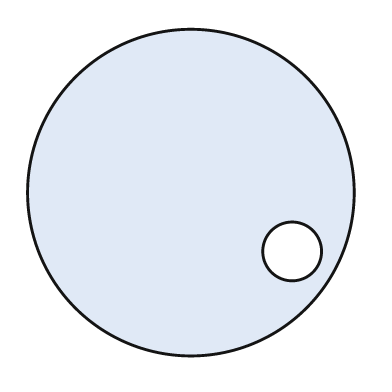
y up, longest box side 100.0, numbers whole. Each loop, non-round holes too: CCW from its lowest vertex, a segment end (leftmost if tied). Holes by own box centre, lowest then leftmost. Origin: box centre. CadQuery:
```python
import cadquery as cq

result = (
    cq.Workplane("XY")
    .moveTo(0.0, 0.0)
    .circle(50.0)
    .moveTo(31.0, -18.0)
    .circle(9.0)
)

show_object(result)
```